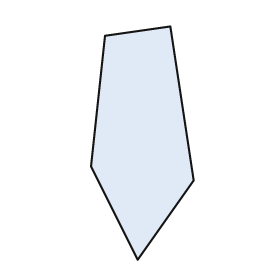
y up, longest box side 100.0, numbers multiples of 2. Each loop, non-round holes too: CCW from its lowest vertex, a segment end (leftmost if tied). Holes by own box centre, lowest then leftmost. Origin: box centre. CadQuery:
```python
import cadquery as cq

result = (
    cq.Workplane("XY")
    .moveTo(-2.0, -50.0)
    .lineTo(22.0, -16.0)
    .lineTo(12.0, 50.0)
    .lineTo(-16.0, 46.0)
    .lineTo(-22.0, -10.0)
    .close()
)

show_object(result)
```